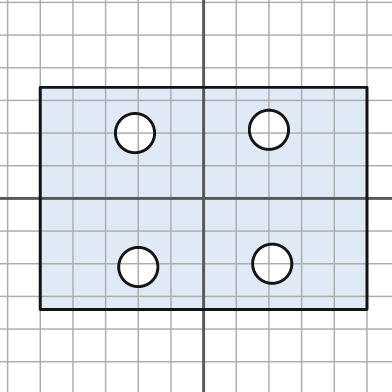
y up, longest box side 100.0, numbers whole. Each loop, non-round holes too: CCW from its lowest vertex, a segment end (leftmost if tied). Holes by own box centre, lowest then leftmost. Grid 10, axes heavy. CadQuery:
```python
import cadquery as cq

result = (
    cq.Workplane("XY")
    .moveTo(-50.0, -34.0)
    .lineTo(50.0, -34.0)
    .lineTo(50.0, 34.0)
    .lineTo(-50.0, 34.0)
    .close()
    .moveTo(-20.0, -21.0)
    .circle(6.0)
    .moveTo(21.0, -20.0)
    .circle(6.0)
    .moveTo(-21.0, 20.0)
    .circle(6.0)
    .moveTo(20.0, 21.0)
    .circle(6.0)
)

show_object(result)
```